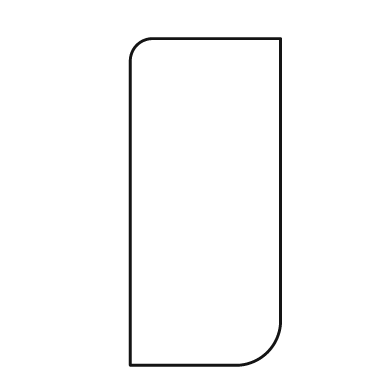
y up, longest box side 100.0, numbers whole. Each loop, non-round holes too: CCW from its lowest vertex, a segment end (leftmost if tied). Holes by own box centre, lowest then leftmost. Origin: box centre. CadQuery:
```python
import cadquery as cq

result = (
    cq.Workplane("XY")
    .moveTo(-23.0, -50.0)
    .lineTo(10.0, -50.0)
    .threePointArc((19.0, -46.0), (23.0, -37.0))
    .lineTo(23.0, 50.0)
    .lineTo(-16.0, 50.0)
    .threePointArc((-21.0, 48.0), (-23.0, 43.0))
    .close()
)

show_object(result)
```